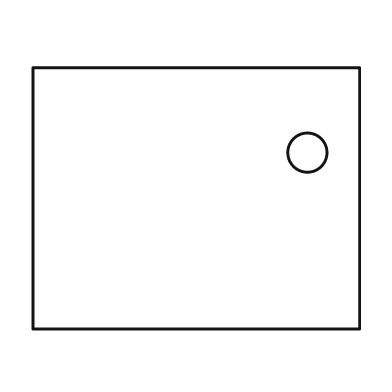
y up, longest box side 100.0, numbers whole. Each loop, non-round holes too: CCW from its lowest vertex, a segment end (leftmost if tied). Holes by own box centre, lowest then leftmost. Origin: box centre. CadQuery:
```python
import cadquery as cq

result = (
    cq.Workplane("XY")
    .moveTo(-50.0, -40.0)
    .lineTo(50.0, -40.0)
    .lineTo(50.0, 40.0)
    .lineTo(-50.0, 40.0)
    .close()
    .moveTo(34.0, 14.0)
    .circle(6.0)
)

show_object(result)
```